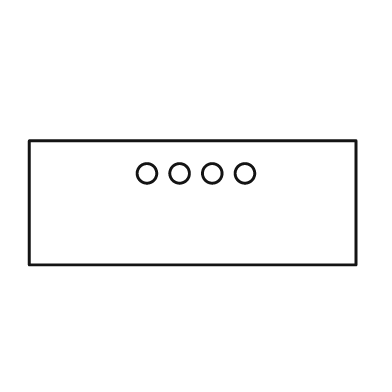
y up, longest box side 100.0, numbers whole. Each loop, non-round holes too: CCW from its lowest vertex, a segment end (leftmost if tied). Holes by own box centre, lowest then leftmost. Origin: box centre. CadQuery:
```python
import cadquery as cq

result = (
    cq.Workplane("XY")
    .moveTo(-50.0, -19.0)
    .lineTo(50.0, -19.0)
    .lineTo(50.0, 19.0)
    .lineTo(-50.0, 19.0)
    .close()
    .moveTo(-14.0, 9.0)
    .circle(3.0)
    .moveTo(-4.0, 9.0)
    .circle(3.0)
    .moveTo(6.0, 9.0)
    .circle(3.0)
    .moveTo(16.0, 9.0)
    .circle(3.0)
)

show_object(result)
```